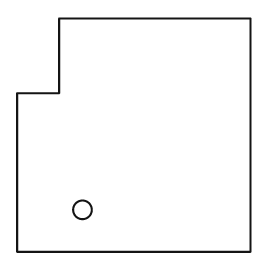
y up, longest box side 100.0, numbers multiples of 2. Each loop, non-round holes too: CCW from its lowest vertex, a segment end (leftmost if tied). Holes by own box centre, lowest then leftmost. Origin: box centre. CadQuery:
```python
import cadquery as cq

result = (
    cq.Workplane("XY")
    .moveTo(-50.0, -50.0)
    .lineTo(50.0, -50.0)
    .lineTo(50.0, 50.0)
    .lineTo(-32.0, 50.0)
    .lineTo(-32.0, 18.0)
    .lineTo(-50.0, 18.0)
    .close()
    .moveTo(-22.0, -32.0)
    .circle(4.0)
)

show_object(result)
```